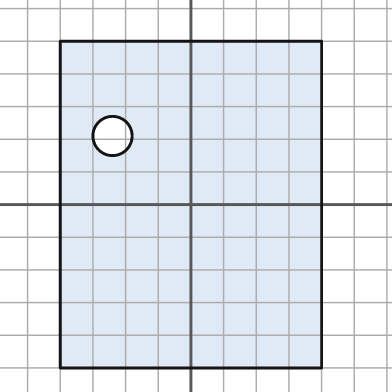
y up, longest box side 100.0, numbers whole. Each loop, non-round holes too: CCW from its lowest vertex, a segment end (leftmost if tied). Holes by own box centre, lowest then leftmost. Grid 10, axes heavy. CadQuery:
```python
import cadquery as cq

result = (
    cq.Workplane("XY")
    .moveTo(-40.0, -50.0)
    .lineTo(40.0, -50.0)
    .lineTo(40.0, 50.0)
    .lineTo(-40.0, 50.0)
    .close()
    .moveTo(-24.0, 21.0)
    .circle(6.0)
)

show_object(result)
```